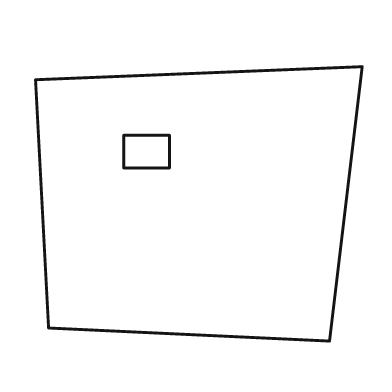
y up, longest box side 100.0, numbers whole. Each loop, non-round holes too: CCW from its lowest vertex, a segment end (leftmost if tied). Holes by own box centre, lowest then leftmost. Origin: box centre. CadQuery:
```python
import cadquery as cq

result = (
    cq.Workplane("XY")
    .moveTo(40.0, -42.0)
    .lineTo(50.0, 42.0)
    .lineTo(-50.0, 38.0)
    .lineTo(-46.0, -38.0)
    .close()
    .moveTo(-23.0, 11.0)
    .lineTo(-9.0, 11.0)
    .lineTo(-9.0, 21.0)
    .lineTo(-23.0, 21.0)
    .close()
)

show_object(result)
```